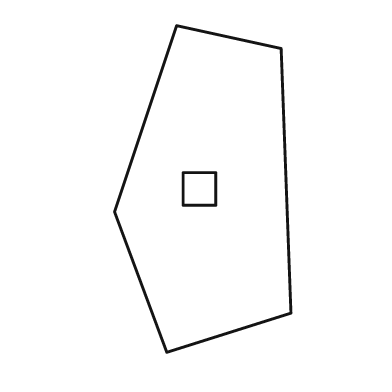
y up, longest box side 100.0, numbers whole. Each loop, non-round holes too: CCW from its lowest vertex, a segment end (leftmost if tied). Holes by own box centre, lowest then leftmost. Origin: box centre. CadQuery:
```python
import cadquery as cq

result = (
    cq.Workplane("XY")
    .moveTo(-11.0, -50.0)
    .lineTo(27.0, -38.0)
    .lineTo(24.0, 43.0)
    .lineTo(-8.0, 50.0)
    .lineTo(-27.0, -7.0)
    .close()
    .moveTo(-6.0, -5.0)
    .lineTo(4.0, -5.0)
    .lineTo(4.0, 5.0)
    .lineTo(-6.0, 5.0)
    .close()
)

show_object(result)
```